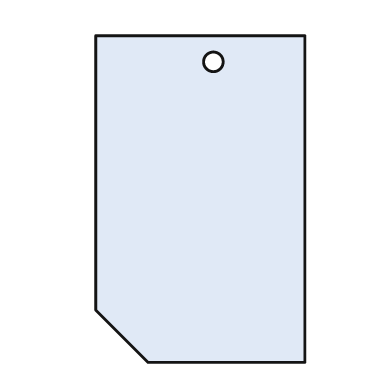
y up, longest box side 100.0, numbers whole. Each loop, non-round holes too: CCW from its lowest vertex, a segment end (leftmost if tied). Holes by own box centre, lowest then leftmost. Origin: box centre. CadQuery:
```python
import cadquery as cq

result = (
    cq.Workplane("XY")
    .moveTo(-16.0, -50.0)
    .lineTo(32.0, -50.0)
    .lineTo(32.0, 50.0)
    .lineTo(-32.0, 50.0)
    .lineTo(-32.0, -34.0)
    .close()
    .moveTo(4.0, 42.0)
    .circle(3.0)
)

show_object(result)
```